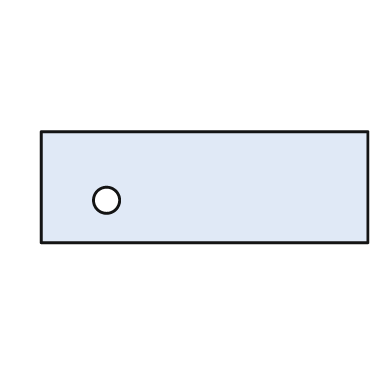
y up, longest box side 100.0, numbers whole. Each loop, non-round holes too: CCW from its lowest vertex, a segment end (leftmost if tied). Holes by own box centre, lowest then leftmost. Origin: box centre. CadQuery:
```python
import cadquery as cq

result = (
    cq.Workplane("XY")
    .moveTo(-50.0, -17.0)
    .lineTo(50.0, -17.0)
    .lineTo(50.0, 17.0)
    .lineTo(-50.0, 17.0)
    .close()
    .moveTo(-30.0, -4.0)
    .circle(4.0)
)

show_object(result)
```